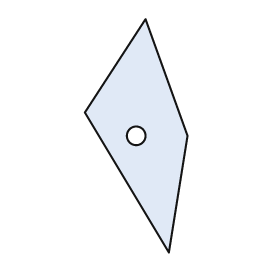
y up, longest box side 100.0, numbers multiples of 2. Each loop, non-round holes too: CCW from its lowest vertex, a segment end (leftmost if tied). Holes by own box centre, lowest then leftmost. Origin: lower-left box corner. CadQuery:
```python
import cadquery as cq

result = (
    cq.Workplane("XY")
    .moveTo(36.0, 0.0)
    .lineTo(44.0, 50.0)
    .lineTo(26.0, 100.0)
    .lineTo(0.0, 60.0)
    .close()
    .moveTo(22.0, 50.0)
    .circle(4.0)
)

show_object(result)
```